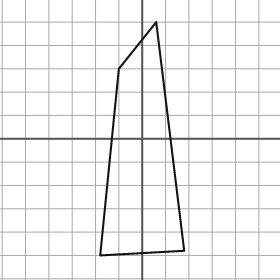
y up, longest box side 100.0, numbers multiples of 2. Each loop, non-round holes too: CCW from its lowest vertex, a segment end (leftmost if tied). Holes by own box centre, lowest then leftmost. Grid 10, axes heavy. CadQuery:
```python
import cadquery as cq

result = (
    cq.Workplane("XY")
    .moveTo(-18.0, -50.0)
    .lineTo(18.0, -48.0)
    .lineTo(6.0, 50.0)
    .lineTo(-10.0, 30.0)
    .close()
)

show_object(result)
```